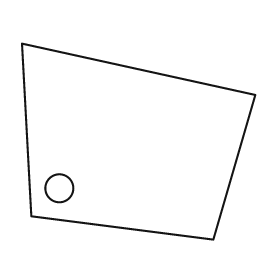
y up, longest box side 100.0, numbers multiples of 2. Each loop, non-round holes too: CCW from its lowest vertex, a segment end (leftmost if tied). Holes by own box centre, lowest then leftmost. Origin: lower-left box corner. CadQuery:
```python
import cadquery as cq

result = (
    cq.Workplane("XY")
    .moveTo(82.0, 0.0)
    .lineTo(100.0, 62.0)
    .lineTo(0.0, 84.0)
    .lineTo(4.0, 10.0)
    .close()
    .moveTo(16.0, 22.0)
    .circle(6.0)
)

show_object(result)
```